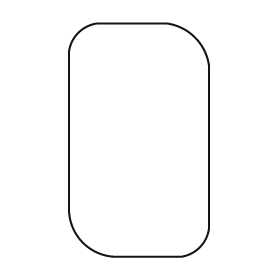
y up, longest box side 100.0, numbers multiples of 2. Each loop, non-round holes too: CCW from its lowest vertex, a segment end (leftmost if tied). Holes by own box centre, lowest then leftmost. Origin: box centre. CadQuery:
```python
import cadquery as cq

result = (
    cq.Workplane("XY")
    .moveTo(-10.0, -50.0)
    .lineTo(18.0, -50.0)
    .threePointArc((26.0, -46.0), (30.0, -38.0))
    .lineTo(30.0, 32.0)
    .threePointArc((24.0, 44.0), (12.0, 50.0))
    .lineTo(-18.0, 50.0)
    .threePointArc((-26.0, 46.0), (-30.0, 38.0))
    .lineTo(-30.0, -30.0)
    .threePointArc((-24.0, -44.0), (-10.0, -50.0))
    .close()
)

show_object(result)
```